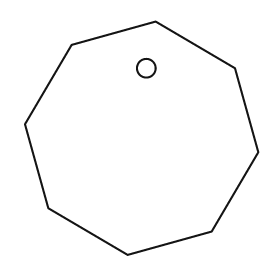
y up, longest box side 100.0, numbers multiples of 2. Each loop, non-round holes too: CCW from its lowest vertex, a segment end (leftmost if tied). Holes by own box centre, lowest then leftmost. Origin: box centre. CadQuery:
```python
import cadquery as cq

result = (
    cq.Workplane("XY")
    .moveTo(-6.0, -50.0)
    .lineTo(30.0, -40.0)
    .lineTo(50.0, -6.0)
    .lineTo(40.0, 30.0)
    .lineTo(6.0, 50.0)
    .lineTo(-30.0, 40.0)
    .lineTo(-50.0, 6.0)
    .lineTo(-40.0, -30.0)
    .close()
    .moveTo(2.0, 30.0)
    .circle(4.0)
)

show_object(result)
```